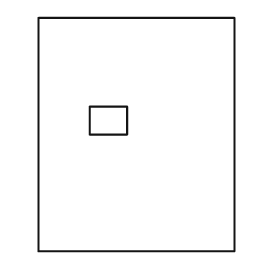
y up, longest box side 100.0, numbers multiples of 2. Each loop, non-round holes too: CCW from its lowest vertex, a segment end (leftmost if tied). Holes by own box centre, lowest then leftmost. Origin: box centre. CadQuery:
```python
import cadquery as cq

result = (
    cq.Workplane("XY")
    .moveTo(-42.0, -50.0)
    .lineTo(42.0, -50.0)
    .lineTo(42.0, 50.0)
    .lineTo(-42.0, 50.0)
    .close()
    .moveTo(-20.0, 0.0)
    .lineTo(-4.0, 0.0)
    .lineTo(-4.0, 12.0)
    .lineTo(-20.0, 12.0)
    .close()
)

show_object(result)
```